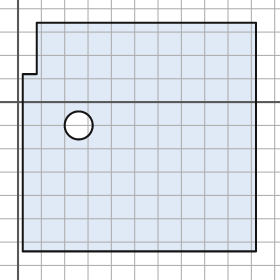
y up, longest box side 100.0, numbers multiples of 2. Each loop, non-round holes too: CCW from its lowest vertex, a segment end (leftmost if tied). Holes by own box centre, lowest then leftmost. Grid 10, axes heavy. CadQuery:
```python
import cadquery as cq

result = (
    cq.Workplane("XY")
    .moveTo(2.0, -64.0)
    .lineTo(102.0, -64.0)
    .lineTo(102.0, 34.0)
    .lineTo(8.0, 34.0)
    .lineTo(8.0, 12.0)
    .lineTo(2.0, 12.0)
    .close()
    .moveTo(26.0, -10.0)
    .circle(6.0)
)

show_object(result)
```